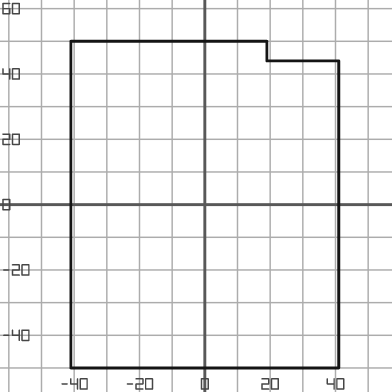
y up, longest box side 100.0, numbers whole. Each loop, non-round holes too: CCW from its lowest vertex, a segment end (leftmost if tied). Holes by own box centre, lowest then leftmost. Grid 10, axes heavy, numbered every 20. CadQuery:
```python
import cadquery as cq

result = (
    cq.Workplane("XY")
    .moveTo(-41.0, -50.0)
    .lineTo(41.0, -50.0)
    .lineTo(41.0, 44.0)
    .lineTo(19.0, 44.0)
    .lineTo(19.0, 50.0)
    .lineTo(-41.0, 50.0)
    .close()
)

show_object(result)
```